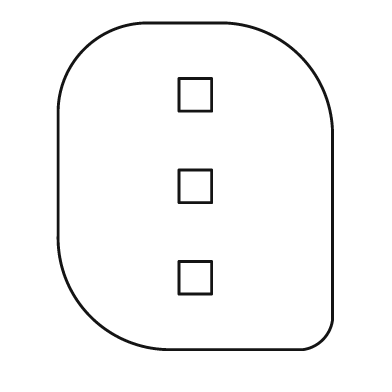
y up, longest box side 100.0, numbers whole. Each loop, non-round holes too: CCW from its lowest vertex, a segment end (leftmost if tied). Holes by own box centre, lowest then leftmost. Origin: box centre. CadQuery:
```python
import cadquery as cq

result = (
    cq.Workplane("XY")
    .moveTo(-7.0, -50.0)
    .lineTo(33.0, -50.0)
    .threePointArc((39.0, -47.0), (42.0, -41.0))
    .lineTo(42.0, 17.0)
    .threePointArc((32.0, 40.0), (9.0, 50.0))
    .lineTo(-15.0, 50.0)
    .threePointArc((-34.0, 42.0), (-42.0, 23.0))
    .lineTo(-42.0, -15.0)
    .threePointArc((-32.0, -40.0), (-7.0, -50.0))
    .close()
    .moveTo(-5.0, -33.0)
    .lineTo(5.0, -33.0)
    .lineTo(5.0, -23.0)
    .lineTo(-5.0, -23.0)
    .close()
    .moveTo(-5.0, -5.0)
    .lineTo(5.0, -5.0)
    .lineTo(5.0, 5.0)
    .lineTo(-5.0, 5.0)
    .close()
    .moveTo(-5.0, 23.0)
    .lineTo(5.0, 23.0)
    .lineTo(5.0, 33.0)
    .lineTo(-5.0, 33.0)
    .close()
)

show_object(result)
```